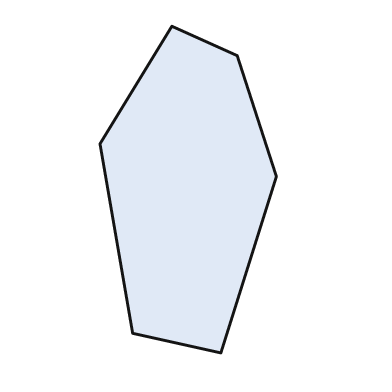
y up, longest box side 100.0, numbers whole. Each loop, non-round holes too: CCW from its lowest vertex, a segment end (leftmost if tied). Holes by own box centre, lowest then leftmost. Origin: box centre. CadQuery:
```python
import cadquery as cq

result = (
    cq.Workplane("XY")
    .moveTo(10.0, -50.0)
    .lineTo(27.0, 4.0)
    .lineTo(15.0, 41.0)
    .lineTo(-5.0, 50.0)
    .lineTo(-27.0, 14.0)
    .lineTo(-17.0, -44.0)
    .close()
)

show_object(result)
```